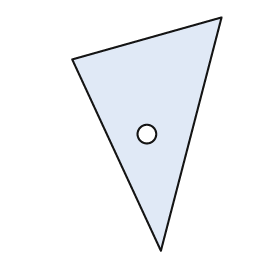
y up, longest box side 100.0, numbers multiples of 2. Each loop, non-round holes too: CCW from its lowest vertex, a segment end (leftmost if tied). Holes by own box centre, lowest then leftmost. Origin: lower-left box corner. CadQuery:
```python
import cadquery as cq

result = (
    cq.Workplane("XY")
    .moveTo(38.0, 0.0)
    .lineTo(64.0, 100.0)
    .lineTo(0.0, 82.0)
    .close()
    .moveTo(32.0, 50.0)
    .circle(4.0)
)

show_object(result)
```